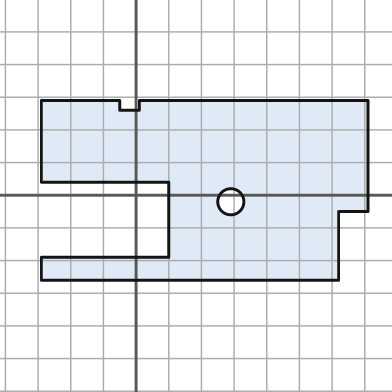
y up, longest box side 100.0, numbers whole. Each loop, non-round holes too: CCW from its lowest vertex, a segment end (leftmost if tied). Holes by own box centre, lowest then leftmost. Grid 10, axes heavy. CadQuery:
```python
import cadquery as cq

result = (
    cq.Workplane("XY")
    .moveTo(-29.0, -26.0)
    .lineTo(62.0, -26.0)
    .lineTo(62.0, -5.0)
    .lineTo(71.0, -5.0)
    .lineTo(71.0, 29.0)
    .lineTo(1.0, 29.0)
    .lineTo(1.0, 26.0)
    .lineTo(-5.0, 26.0)
    .lineTo(-5.0, 29.0)
    .lineTo(-29.0, 29.0)
    .lineTo(-29.0, 4.0)
    .lineTo(10.0, 4.0)
    .lineTo(10.0, -19.0)
    .lineTo(-29.0, -19.0)
    .close()
    .moveTo(29.0, -2.0)
    .circle(4.0)
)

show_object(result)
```